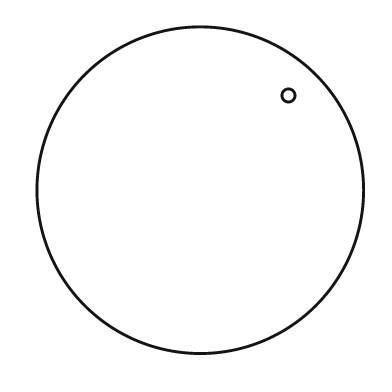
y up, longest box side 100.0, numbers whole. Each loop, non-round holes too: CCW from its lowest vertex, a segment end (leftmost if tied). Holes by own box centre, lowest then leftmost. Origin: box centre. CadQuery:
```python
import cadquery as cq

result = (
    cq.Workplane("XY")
    .moveTo(0.0, 0.0)
    .circle(50.0)
    .moveTo(27.0, 29.0)
    .circle(2.0)
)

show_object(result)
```